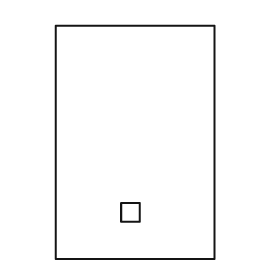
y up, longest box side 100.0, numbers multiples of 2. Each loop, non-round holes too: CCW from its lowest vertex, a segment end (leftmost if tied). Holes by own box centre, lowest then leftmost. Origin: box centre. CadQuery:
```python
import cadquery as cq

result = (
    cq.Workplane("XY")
    .moveTo(-34.0, -50.0)
    .lineTo(34.0, -50.0)
    .lineTo(34.0, 50.0)
    .lineTo(-34.0, 50.0)
    .close()
    .moveTo(-6.0, -34.0)
    .lineTo(2.0, -34.0)
    .lineTo(2.0, -26.0)
    .lineTo(-6.0, -26.0)
    .close()
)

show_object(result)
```